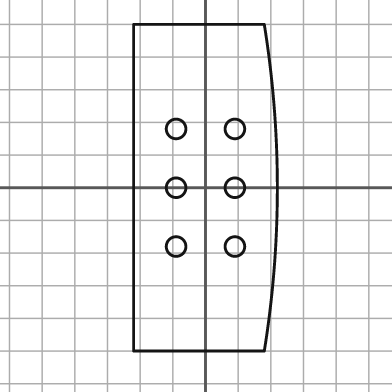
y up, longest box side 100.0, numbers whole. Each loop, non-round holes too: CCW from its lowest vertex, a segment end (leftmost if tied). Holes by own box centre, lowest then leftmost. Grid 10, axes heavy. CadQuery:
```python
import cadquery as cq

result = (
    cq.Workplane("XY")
    .moveTo(-22.0, -50.0)
    .lineTo(18.0, -50.0)
    .threePointArc((22.0, 0.0), (18.0, 50.0))
    .lineTo(-22.0, 50.0)
    .close()
    .moveTo(-9.0, -18.0)
    .circle(3.0)
    .moveTo(9.0, -18.0)
    .circle(3.0)
    .moveTo(-9.0, 0.0)
    .circle(3.0)
    .moveTo(9.0, 0.0)
    .circle(3.0)
    .moveTo(-9.0, 18.0)
    .circle(3.0)
    .moveTo(9.0, 18.0)
    .circle(3.0)
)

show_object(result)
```